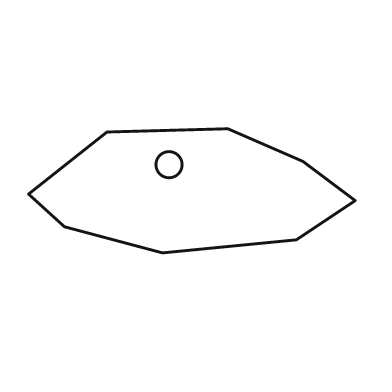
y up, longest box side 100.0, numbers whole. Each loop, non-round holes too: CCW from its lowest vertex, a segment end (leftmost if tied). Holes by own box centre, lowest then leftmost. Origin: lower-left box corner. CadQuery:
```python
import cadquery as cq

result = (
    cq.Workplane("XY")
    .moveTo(41.0, 0.0)
    .lineTo(82.0, 4.0)
    .lineTo(100.0, 16.0)
    .lineTo(84.0, 28.0)
    .lineTo(61.0, 38.0)
    .lineTo(24.0, 37.0)
    .lineTo(0.0, 18.0)
    .lineTo(11.0, 8.0)
    .close()
    .moveTo(43.0, 27.0)
    .circle(4.0)
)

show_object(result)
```